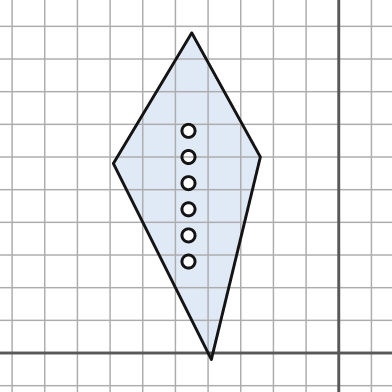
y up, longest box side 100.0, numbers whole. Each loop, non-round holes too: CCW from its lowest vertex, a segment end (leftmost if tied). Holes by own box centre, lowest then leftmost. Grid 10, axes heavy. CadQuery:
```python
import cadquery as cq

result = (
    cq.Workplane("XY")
    .moveTo(-39.0, -2.0)
    .lineTo(-24.0, 60.0)
    .lineTo(-45.0, 98.0)
    .lineTo(-69.0, 58.0)
    .close()
    .moveTo(-46.0, 28.0)
    .circle(2.0)
    .moveTo(-46.0, 36.0)
    .circle(2.0)
    .moveTo(-46.0, 44.0)
    .circle(2.0)
    .moveTo(-46.0, 52.0)
    .circle(2.0)
    .moveTo(-46.0, 60.0)
    .circle(2.0)
    .moveTo(-46.0, 68.0)
    .circle(2.0)
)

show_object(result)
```